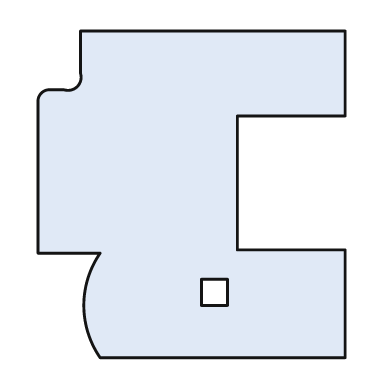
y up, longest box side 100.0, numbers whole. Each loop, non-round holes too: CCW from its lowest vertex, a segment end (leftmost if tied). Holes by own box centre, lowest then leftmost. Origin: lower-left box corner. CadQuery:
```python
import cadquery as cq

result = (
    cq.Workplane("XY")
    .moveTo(19.0, 0.0)
    .lineTo(94.0, 0.0)
    .lineTo(94.0, 33.0)
    .lineTo(61.0, 33.0)
    .lineTo(61.0, 74.0)
    .lineTo(94.0, 74.0)
    .lineTo(94.0, 100.0)
    .lineTo(13.0, 100.0)
    .lineTo(13.0, 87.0)
    .threePointArc((12.0, 83.0), (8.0, 82.0))
    .lineTo(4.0, 82.0)
    .threePointArc((1.0, 81.0), (0.0, 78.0))
    .lineTo(0.0, 32.0)
    .lineTo(19.0, 32.0)
    .threePointArc((14.0, 16.0), (19.0, 0.0))
    .close()
    .moveTo(50.0, 16.0)
    .lineTo(58.0, 16.0)
    .lineTo(58.0, 24.0)
    .lineTo(50.0, 24.0)
    .close()
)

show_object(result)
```